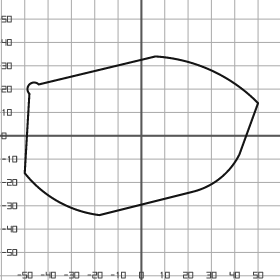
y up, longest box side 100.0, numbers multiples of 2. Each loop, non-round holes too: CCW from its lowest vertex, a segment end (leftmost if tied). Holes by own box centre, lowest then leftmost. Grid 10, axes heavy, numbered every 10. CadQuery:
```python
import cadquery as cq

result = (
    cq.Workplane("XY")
    .moveTo(-18.0, -34.0)
    .lineTo(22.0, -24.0)
    .threePointArc((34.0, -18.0), (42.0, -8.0))
    .lineTo(50.0, 14.0)
    .threePointArc((30.0, 28.0), (6.0, 34.0))
    .lineTo(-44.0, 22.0)
    .threePointArc((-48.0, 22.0), (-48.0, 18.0))
    .lineTo(-50.0, -16.0)
    .threePointArc((-36.0, -28.0), (-18.0, -34.0))
    .close()
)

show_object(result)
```